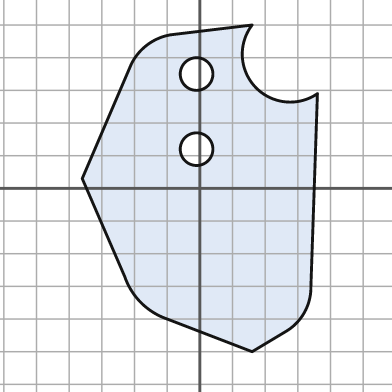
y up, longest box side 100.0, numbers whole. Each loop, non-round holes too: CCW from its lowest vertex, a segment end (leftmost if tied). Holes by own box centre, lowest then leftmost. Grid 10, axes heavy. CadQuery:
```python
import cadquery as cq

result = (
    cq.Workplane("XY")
    .moveTo(16.0, -50.0)
    .lineTo(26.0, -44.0)
    .threePointArc((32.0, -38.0), (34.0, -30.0))
    .lineTo(36.0, 29.0)
    .threePointArc((17.0, 31.0), (16.0, 50.0))
    .lineTo(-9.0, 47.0)
    .threePointArc((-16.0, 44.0), (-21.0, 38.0))
    .lineTo(-36.0, 3.0)
    .lineTo(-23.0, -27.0)
    .threePointArc((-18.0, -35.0), (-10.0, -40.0))
    .close()
    .moveTo(-1.0, 12.0)
    .circle(5.0)
    .moveTo(-1.0, 35.0)
    .circle(5.0)
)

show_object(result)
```